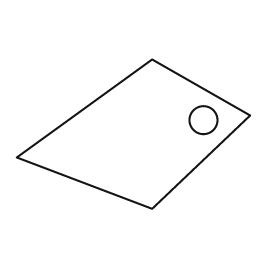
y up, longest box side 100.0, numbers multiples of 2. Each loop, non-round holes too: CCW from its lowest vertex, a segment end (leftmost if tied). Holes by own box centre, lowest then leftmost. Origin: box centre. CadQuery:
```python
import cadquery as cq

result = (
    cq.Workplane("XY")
    .moveTo(8.0, -32.0)
    .lineTo(50.0, 8.0)
    .lineTo(8.0, 32.0)
    .lineTo(-50.0, -10.0)
    .close()
    .moveTo(30.0, 6.0)
    .circle(6.0)
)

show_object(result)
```